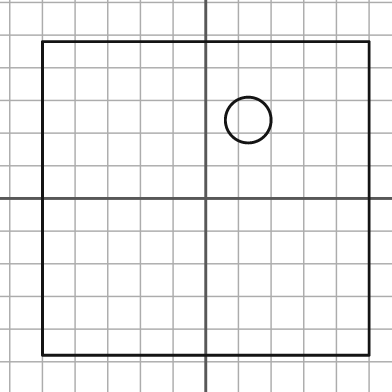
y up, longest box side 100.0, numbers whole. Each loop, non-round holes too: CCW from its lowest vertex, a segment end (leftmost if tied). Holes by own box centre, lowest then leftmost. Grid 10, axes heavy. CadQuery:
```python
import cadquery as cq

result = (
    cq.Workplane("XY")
    .moveTo(-50.0, -48.0)
    .lineTo(50.0, -48.0)
    .lineTo(50.0, 48.0)
    .lineTo(-50.0, 48.0)
    .close()
    .moveTo(13.0, 24.0)
    .circle(7.0)
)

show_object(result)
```